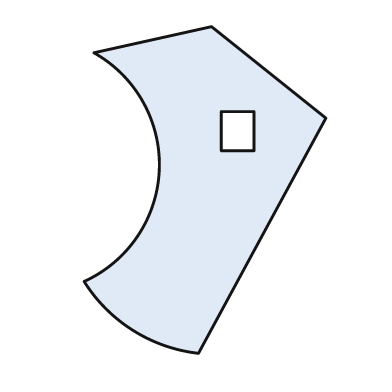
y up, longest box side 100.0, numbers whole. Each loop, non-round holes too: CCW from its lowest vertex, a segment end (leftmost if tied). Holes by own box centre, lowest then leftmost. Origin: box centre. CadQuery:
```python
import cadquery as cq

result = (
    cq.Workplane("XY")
    .moveTo(-2.0, -50.0)
    .lineTo(37.0, 22.0)
    .lineTo(2.0, 50.0)
    .lineTo(-34.0, 42.0)
    .threePointArc((-14.0, 6.0), (-37.0, -28.0))
    .threePointArc((-22.0, -43.0), (-2.0, -50.0))
    .close()
    .moveTo(5.0, 12.0)
    .lineTo(15.0, 12.0)
    .lineTo(15.0, 24.0)
    .lineTo(5.0, 24.0)
    .close()
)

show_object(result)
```